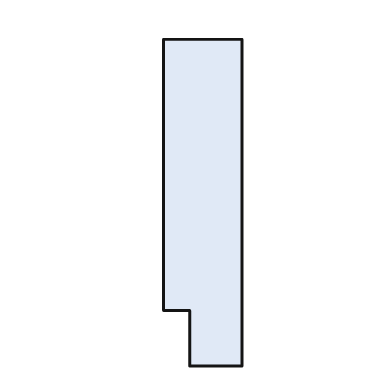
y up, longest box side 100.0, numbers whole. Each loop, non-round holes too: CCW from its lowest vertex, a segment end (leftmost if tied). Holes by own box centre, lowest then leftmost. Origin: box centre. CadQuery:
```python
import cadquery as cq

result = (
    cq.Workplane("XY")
    .moveTo(-4.0, -50.0)
    .lineTo(12.0, -50.0)
    .lineTo(12.0, 50.0)
    .lineTo(-12.0, 50.0)
    .lineTo(-12.0, -33.0)
    .lineTo(-4.0, -33.0)
    .close()
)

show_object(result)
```